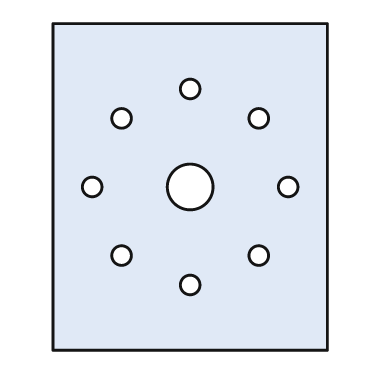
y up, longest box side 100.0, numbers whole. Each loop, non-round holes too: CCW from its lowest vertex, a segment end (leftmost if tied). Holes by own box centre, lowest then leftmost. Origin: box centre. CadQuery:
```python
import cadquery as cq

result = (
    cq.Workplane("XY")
    .moveTo(-42.0, -50.0)
    .lineTo(42.0, -50.0)
    .lineTo(42.0, 50.0)
    .lineTo(-42.0, 50.0)
    .close()
    .moveTo(0.0, -30.0)
    .circle(3.0)
    .moveTo(-21.0, -21.0)
    .circle(3.0)
    .moveTo(21.0, -21.0)
    .circle(3.0)
    .moveTo(-30.0, 0.0)
    .circle(3.0)
    .moveTo(0.0, 0.0)
    .circle(7.0)
    .moveTo(30.0, 0.0)
    .circle(3.0)
    .moveTo(-21.0, 21.0)
    .circle(3.0)
    .moveTo(21.0, 21.0)
    .circle(3.0)
    .moveTo(0.0, 30.0)
    .circle(3.0)
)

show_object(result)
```